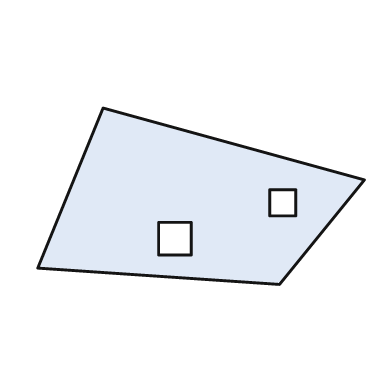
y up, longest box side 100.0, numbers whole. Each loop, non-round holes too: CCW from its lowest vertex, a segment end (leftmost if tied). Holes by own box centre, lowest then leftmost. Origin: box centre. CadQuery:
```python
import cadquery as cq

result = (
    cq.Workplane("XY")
    .moveTo(24.0, -27.0)
    .lineTo(50.0, 5.0)
    .lineTo(-30.0, 27.0)
    .lineTo(-50.0, -22.0)
    .close()
    .moveTo(-13.0, -18.0)
    .lineTo(-3.0, -18.0)
    .lineTo(-3.0, -8.0)
    .lineTo(-13.0, -8.0)
    .close()
    .moveTo(21.0, -6.0)
    .lineTo(29.0, -6.0)
    .lineTo(29.0, 2.0)
    .lineTo(21.0, 2.0)
    .close()
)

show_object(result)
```